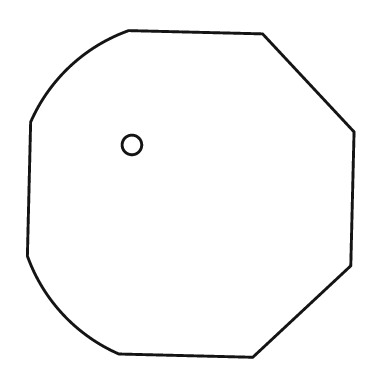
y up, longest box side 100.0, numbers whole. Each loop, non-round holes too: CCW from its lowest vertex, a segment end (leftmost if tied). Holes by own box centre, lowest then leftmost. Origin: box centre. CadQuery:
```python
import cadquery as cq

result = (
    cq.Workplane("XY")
    .moveTo(19.0, -50.0)
    .lineTo(49.0, -22.0)
    .lineTo(50.0, 19.0)
    .lineTo(22.0, 49.0)
    .lineTo(-19.0, 50.0)
    .threePointArc((-37.0, 39.0), (-49.0, 22.0))
    .lineTo(-50.0, -19.0)
    .threePointArc((-39.0, -37.0), (-22.0, -49.0))
    .close()
    .moveTo(-18.0, 15.0)
    .circle(3.0)
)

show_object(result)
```